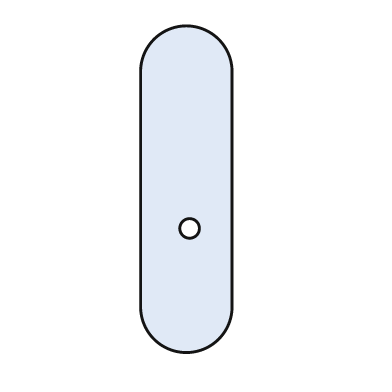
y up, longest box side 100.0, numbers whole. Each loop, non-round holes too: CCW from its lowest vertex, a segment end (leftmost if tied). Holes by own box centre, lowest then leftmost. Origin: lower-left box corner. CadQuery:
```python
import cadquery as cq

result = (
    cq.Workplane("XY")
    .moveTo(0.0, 14.0)
    .threePointArc((14.0, 0.0), (28.0, 14.0))
    .lineTo(28.0, 86.0)
    .threePointArc((14.0, 100.0), (0.0, 86.0))
    .close()
    .moveTo(15.0, 38.0)
    .circle(3.0)
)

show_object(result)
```